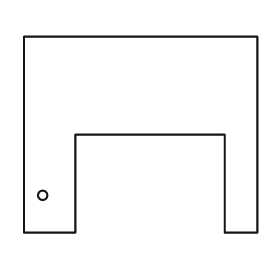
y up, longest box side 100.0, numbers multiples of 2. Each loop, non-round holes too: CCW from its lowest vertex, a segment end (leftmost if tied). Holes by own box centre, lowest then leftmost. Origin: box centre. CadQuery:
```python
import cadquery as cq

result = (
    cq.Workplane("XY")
    .moveTo(-50.0, -42.0)
    .lineTo(-28.0, -42.0)
    .lineTo(-28.0, 0.0)
    .lineTo(36.0, 0.0)
    .lineTo(36.0, -42.0)
    .lineTo(50.0, -42.0)
    .lineTo(50.0, 42.0)
    .lineTo(-50.0, 42.0)
    .close()
    .moveTo(-42.0, -26.0)
    .circle(2.0)
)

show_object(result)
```